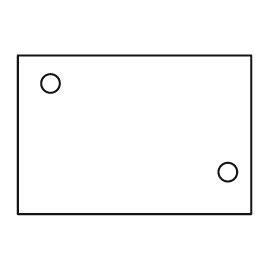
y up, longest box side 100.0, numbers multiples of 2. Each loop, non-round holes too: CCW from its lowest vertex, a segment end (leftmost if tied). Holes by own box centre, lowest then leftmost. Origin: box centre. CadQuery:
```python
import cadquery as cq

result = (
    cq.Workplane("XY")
    .moveTo(-50.0, -34.0)
    .lineTo(50.0, -34.0)
    .lineTo(50.0, 34.0)
    .lineTo(-50.0, 34.0)
    .close()
    .moveTo(40.0, -16.0)
    .circle(4.0)
    .moveTo(-36.0, 22.0)
    .circle(4.0)
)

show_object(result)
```